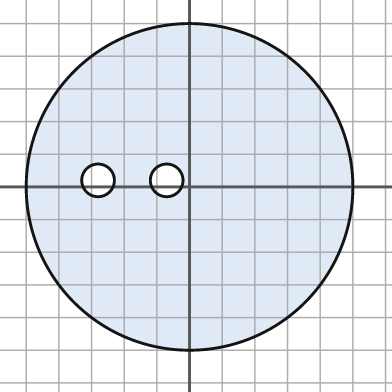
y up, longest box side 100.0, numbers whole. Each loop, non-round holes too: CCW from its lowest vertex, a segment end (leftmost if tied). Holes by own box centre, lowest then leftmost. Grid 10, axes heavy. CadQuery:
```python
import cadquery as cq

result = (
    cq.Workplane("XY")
    .moveTo(0.0, 0.0)
    .circle(50.0)
    .moveTo(-28.0, 2.0)
    .circle(5.0)
    .moveTo(-7.0, 2.0)
    .circle(5.0)
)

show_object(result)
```